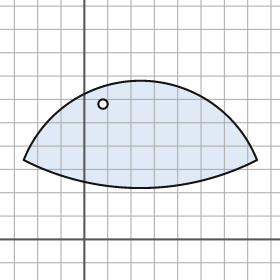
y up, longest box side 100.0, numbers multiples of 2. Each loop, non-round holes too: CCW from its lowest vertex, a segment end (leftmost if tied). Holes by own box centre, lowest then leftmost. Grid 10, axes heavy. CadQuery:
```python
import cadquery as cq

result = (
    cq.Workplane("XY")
    .moveTo(-26.0, 34.0)
    .threePointArc((24.0, 22.0), (74.0, 34.0))
    .threePointArc((24.0, 68.0), (-26.0, 34.0))
    .close()
    .moveTo(8.0, 58.0)
    .circle(2.0)
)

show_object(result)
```